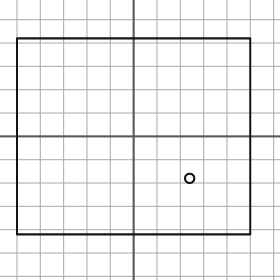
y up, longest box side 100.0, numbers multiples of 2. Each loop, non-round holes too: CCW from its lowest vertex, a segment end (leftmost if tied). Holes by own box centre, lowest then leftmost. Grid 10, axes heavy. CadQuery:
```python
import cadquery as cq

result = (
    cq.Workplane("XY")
    .moveTo(-50.0, -42.0)
    .lineTo(50.0, -42.0)
    .lineTo(50.0, 42.0)
    .lineTo(-50.0, 42.0)
    .close()
    .moveTo(24.0, -18.0)
    .circle(2.0)
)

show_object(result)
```